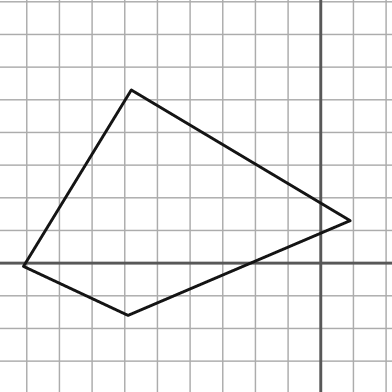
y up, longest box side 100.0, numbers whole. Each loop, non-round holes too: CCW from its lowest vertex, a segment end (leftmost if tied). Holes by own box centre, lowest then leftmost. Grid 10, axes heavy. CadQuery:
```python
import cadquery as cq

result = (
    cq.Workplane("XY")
    .moveTo(-59.0, -16.0)
    .lineTo(9.0, 13.0)
    .lineTo(-58.0, 53.0)
    .lineTo(-91.0, -1.0)
    .close()
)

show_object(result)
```